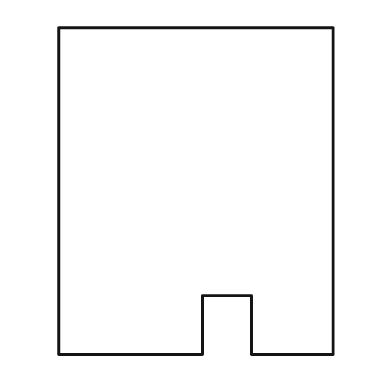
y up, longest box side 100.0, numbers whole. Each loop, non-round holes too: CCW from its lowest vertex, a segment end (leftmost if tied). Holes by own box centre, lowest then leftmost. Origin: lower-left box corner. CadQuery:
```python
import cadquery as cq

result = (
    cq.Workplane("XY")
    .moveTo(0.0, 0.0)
    .lineTo(44.0, 0.0)
    .lineTo(44.0, 18.0)
    .lineTo(59.0, 18.0)
    .lineTo(59.0, 0.0)
    .lineTo(84.0, 0.0)
    .lineTo(84.0, 100.0)
    .lineTo(0.0, 100.0)
    .close()
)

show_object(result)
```